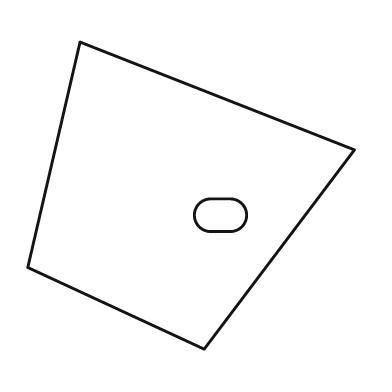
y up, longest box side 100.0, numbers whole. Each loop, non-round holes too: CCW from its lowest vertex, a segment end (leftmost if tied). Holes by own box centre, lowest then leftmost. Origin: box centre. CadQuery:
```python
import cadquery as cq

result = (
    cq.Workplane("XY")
    .moveTo(4.0, -47.0)
    .lineTo(50.0, 14.0)
    .lineTo(-34.0, 47.0)
    .lineTo(-50.0, -22.0)
    .close()
    .moveTo(6.0, -11.0)
    .lineTo(12.0, -11.0)
    .threePointArc((17.0, -6.0), (12.0, -1.0))
    .lineTo(6.0, -1.0)
    .threePointArc((1.0, -6.0), (6.0, -11.0))
    .close()
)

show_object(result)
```